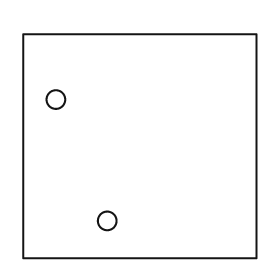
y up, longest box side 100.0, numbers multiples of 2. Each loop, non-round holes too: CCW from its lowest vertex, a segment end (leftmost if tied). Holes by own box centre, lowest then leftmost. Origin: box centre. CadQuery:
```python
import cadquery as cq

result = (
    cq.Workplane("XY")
    .moveTo(-50.0, -48.0)
    .lineTo(50.0, -48.0)
    .lineTo(50.0, 48.0)
    .lineTo(-50.0, 48.0)
    .close()
    .moveTo(-14.0, -32.0)
    .circle(4.0)
    .moveTo(-36.0, 20.0)
    .circle(4.0)
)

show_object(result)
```